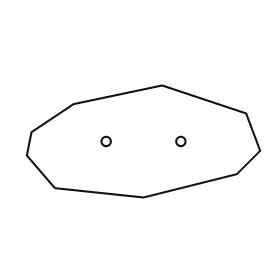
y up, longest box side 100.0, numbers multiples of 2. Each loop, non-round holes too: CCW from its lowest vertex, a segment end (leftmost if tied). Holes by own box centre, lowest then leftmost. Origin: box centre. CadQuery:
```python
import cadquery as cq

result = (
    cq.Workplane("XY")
    .moveTo(0.0, -24.0)
    .lineTo(40.0, -14.0)
    .lineTo(50.0, -4.0)
    .lineTo(44.0, 12.0)
    .lineTo(8.0, 24.0)
    .lineTo(-30.0, 16.0)
    .lineTo(-48.0, 4.0)
    .lineTo(-50.0, -6.0)
    .lineTo(-38.0, -20.0)
    .close()
    .moveTo(-16.0, 0.0)
    .circle(2.0)
    .moveTo(16.0, 0.0)
    .circle(2.0)
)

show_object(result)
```